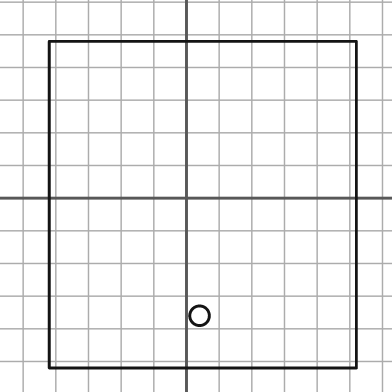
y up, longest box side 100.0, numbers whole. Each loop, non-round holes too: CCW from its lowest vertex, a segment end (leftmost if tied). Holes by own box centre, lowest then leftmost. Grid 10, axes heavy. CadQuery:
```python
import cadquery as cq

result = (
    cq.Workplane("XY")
    .moveTo(-42.0, -52.0)
    .lineTo(52.0, -52.0)
    .lineTo(52.0, 48.0)
    .lineTo(-42.0, 48.0)
    .close()
    .moveTo(4.0, -36.0)
    .circle(3.0)
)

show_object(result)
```